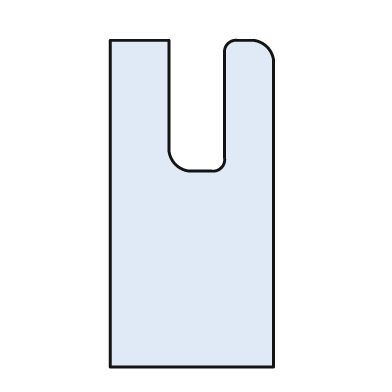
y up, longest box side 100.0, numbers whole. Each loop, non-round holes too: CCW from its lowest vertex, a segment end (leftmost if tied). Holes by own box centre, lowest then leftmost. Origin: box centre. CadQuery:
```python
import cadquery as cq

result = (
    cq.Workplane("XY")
    .moveTo(-25.0, -50.0)
    .lineTo(25.0, -50.0)
    .lineTo(25.0, 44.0)
    .threePointArc((23.0, 48.0), (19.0, 50.0))
    .lineTo(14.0, 50.0)
    .threePointArc((11.0, 49.0), (10.0, 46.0))
    .lineTo(10.0, 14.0)
    .threePointArc((9.0, 11.0), (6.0, 10.0))
    .lineTo(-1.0, 10.0)
    .threePointArc((-5.0, 12.0), (-7.0, 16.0))
    .lineTo(-7.0, 50.0)
    .lineTo(-25.0, 50.0)
    .close()
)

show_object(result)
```